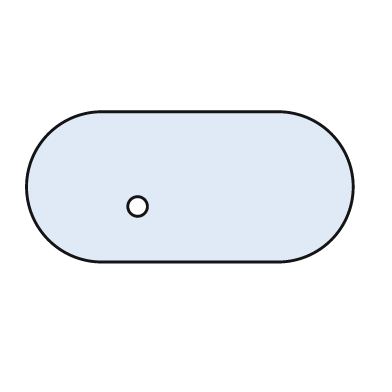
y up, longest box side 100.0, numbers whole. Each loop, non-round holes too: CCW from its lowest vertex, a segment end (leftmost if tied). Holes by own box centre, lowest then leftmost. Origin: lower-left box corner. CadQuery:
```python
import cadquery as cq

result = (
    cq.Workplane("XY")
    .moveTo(23.0, 0.0)
    .lineTo(77.0, 0.0)
    .threePointArc((100.0, 23.0), (77.0, 46.0))
    .lineTo(23.0, 46.0)
    .threePointArc((0.0, 23.0), (23.0, 0.0))
    .close()
    .moveTo(34.0, 17.0)
    .circle(3.0)
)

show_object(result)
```